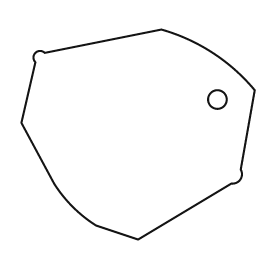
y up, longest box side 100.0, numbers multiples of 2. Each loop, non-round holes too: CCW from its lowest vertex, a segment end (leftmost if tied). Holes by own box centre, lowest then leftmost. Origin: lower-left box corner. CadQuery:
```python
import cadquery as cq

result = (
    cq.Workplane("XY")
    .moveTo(50.0, 0.0)
    .lineTo(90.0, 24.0)
    .threePointArc((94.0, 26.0), (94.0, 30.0))
    .lineTo(100.0, 64.0)
    .threePointArc((82.0, 80.0), (60.0, 90.0))
    .lineTo(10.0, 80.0)
    .threePointArc((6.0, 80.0), (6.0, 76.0))
    .lineTo(0.0, 50.0)
    .lineTo(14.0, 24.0)
    .threePointArc((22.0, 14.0), (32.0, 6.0))
    .close()
    .moveTo(84.0, 60.0)
    .circle(4.0)
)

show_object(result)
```